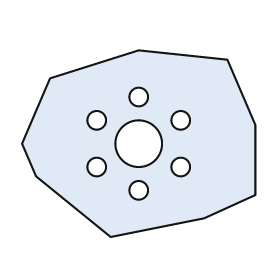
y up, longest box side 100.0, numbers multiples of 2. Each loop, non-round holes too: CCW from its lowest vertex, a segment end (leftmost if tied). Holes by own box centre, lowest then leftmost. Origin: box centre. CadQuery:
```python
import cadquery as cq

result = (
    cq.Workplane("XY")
    .moveTo(-12.0, -40.0)
    .lineTo(28.0, -32.0)
    .lineTo(50.0, -22.0)
    .lineTo(50.0, 8.0)
    .lineTo(38.0, 36.0)
    .lineTo(0.0, 40.0)
    .lineTo(-38.0, 28.0)
    .lineTo(-50.0, 0.0)
    .lineTo(-44.0, -14.0)
    .close()
    .moveTo(0.0, -20.0)
    .circle(4.0)
    .moveTo(-18.0, -10.0)
    .circle(4.0)
    .moveTo(18.0, -10.0)
    .circle(4.0)
    .moveTo(0.0, 0.0)
    .circle(10.0)
    .moveTo(-18.0, 10.0)
    .circle(4.0)
    .moveTo(18.0, 10.0)
    .circle(4.0)
    .moveTo(0.0, 20.0)
    .circle(4.0)
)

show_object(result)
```